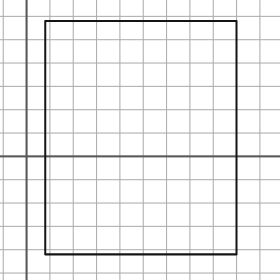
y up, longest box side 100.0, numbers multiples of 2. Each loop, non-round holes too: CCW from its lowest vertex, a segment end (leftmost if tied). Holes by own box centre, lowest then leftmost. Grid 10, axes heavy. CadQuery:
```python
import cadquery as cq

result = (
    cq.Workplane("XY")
    .moveTo(8.0, -42.0)
    .lineTo(90.0, -42.0)
    .lineTo(90.0, 58.0)
    .lineTo(8.0, 58.0)
    .close()
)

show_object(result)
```